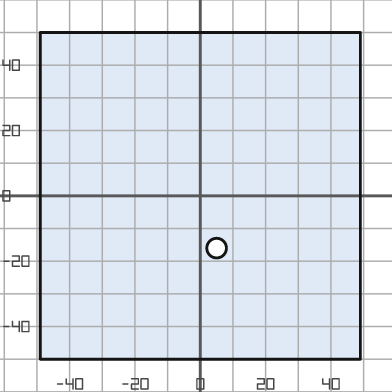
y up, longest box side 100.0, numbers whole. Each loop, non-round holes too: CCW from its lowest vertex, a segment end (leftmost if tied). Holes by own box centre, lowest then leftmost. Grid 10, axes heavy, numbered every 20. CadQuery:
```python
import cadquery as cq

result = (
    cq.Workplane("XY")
    .moveTo(-49.0, -50.0)
    .lineTo(49.0, -50.0)
    .lineTo(49.0, 50.0)
    .lineTo(-49.0, 50.0)
    .close()
    .moveTo(5.0, -16.0)
    .circle(3.0)
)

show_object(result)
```